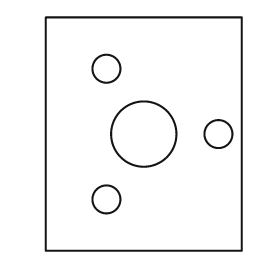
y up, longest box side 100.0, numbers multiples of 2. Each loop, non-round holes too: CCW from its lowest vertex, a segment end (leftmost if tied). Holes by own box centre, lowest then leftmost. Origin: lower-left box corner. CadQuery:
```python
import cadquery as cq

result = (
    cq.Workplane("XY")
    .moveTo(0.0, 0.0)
    .lineTo(84.0, 0.0)
    .lineTo(84.0, 100.0)
    .lineTo(0.0, 100.0)
    .close()
    .moveTo(26.0, 22.0)
    .circle(6.0)
    .moveTo(42.0, 50.0)
    .circle(14.0)
    .moveTo(74.0, 50.0)
    .circle(6.0)
    .moveTo(26.0, 78.0)
    .circle(6.0)
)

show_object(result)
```